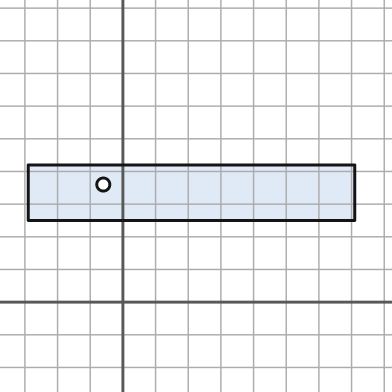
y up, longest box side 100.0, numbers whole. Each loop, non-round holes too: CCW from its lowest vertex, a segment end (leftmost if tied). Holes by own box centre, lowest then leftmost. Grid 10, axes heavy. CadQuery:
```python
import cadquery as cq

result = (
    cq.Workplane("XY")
    .moveTo(-29.0, 25.0)
    .lineTo(71.0, 25.0)
    .lineTo(71.0, 42.0)
    .lineTo(-29.0, 42.0)
    .close()
    .moveTo(-6.0, 36.0)
    .circle(2.0)
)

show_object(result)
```